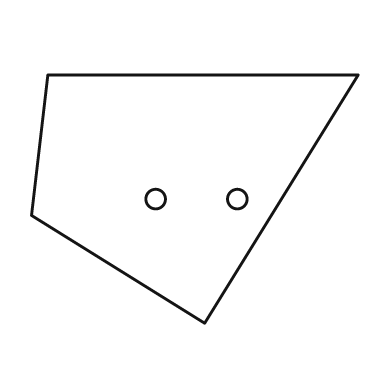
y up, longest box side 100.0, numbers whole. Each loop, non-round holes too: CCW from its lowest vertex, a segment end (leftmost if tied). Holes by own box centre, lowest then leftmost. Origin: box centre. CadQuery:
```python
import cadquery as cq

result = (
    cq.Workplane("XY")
    .moveTo(3.0, -38.0)
    .lineTo(50.0, 38.0)
    .lineTo(-45.0, 38.0)
    .lineTo(-50.0, -5.0)
    .close()
    .moveTo(-12.0, 0.0)
    .circle(3.0)
    .moveTo(13.0, 0.0)
    .circle(3.0)
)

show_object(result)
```